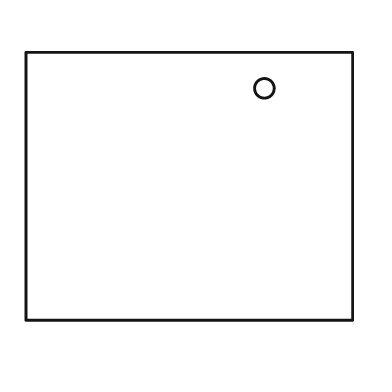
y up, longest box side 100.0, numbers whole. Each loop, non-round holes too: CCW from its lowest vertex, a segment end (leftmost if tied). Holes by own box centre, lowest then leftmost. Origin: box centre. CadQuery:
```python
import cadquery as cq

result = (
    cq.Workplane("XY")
    .moveTo(-50.0, -41.0)
    .lineTo(50.0, -41.0)
    .lineTo(50.0, 41.0)
    .lineTo(-50.0, 41.0)
    .close()
    .moveTo(23.0, 30.0)
    .circle(3.0)
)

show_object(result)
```